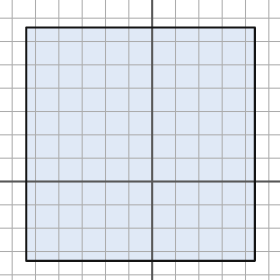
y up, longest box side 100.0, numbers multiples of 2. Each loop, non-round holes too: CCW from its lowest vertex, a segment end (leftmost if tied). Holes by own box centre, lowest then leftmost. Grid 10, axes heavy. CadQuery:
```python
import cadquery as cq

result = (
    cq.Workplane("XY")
    .moveTo(-54.0, -34.0)
    .lineTo(44.0, -34.0)
    .lineTo(44.0, 66.0)
    .lineTo(-54.0, 66.0)
    .close()
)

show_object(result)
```